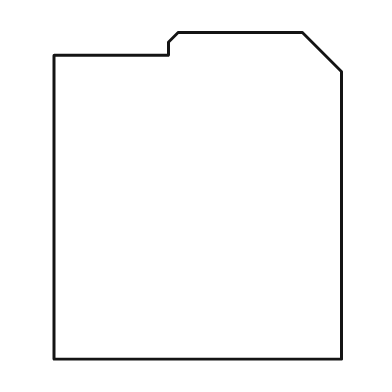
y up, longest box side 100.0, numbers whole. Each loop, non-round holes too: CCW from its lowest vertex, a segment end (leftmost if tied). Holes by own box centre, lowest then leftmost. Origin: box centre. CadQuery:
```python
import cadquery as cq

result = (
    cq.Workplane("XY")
    .moveTo(-44.0, -50.0)
    .lineTo(44.0, -50.0)
    .lineTo(44.0, 38.0)
    .lineTo(32.0, 50.0)
    .lineTo(-6.0, 50.0)
    .lineTo(-9.0, 47.0)
    .lineTo(-9.0, 43.0)
    .lineTo(-44.0, 43.0)
    .close()
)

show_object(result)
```